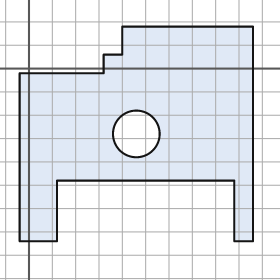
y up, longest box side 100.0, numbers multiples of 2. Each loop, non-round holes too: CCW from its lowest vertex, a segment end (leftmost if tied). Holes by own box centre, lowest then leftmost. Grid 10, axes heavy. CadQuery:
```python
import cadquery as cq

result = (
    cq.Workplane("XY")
    .moveTo(-4.0, -74.0)
    .lineTo(12.0, -74.0)
    .lineTo(12.0, -48.0)
    .lineTo(88.0, -48.0)
    .lineTo(88.0, -74.0)
    .lineTo(96.0, -74.0)
    .lineTo(96.0, 18.0)
    .lineTo(40.0, 18.0)
    .lineTo(40.0, 6.0)
    .lineTo(32.0, 6.0)
    .lineTo(32.0, -2.0)
    .lineTo(-4.0, -2.0)
    .close()
    .moveTo(46.0, -28.0)
    .circle(10.0)
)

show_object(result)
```